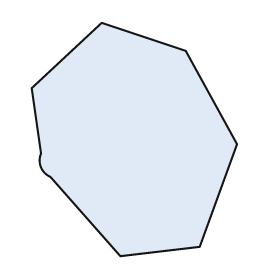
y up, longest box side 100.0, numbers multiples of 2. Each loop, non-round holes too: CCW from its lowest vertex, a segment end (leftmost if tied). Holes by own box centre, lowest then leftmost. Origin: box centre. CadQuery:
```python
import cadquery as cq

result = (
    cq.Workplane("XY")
    .moveTo(-6.0, -50.0)
    .lineTo(28.0, -46.0)
    .lineTo(44.0, -2.0)
    .lineTo(22.0, 38.0)
    .lineTo(-14.0, 50.0)
    .lineTo(-44.0, 22.0)
    .lineTo(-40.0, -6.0)
    .threePointArc((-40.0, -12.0), (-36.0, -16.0))
    .close()
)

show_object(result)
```